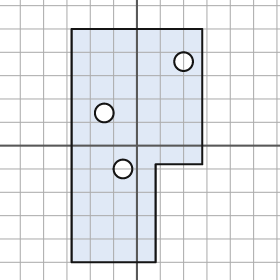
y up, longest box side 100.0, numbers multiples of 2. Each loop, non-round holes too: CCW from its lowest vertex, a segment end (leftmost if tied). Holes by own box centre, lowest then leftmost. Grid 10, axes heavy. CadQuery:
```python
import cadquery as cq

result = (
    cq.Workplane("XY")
    .moveTo(-28.0, -50.0)
    .lineTo(8.0, -50.0)
    .lineTo(8.0, -8.0)
    .lineTo(28.0, -8.0)
    .lineTo(28.0, 50.0)
    .lineTo(-28.0, 50.0)
    .close()
    .moveTo(-6.0, -10.0)
    .circle(4.0)
    .moveTo(-14.0, 14.0)
    .circle(4.0)
    .moveTo(20.0, 36.0)
    .circle(4.0)
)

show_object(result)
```